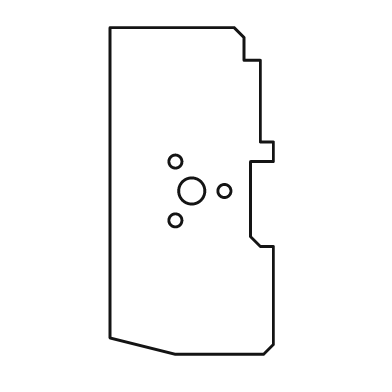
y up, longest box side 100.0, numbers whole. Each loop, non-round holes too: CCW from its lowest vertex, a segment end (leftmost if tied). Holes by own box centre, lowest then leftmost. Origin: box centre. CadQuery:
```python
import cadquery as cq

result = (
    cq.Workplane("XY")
    .moveTo(-5.0, -50.0)
    .lineTo(22.0, -50.0)
    .lineTo(25.0, -47.0)
    .lineTo(25.0, -17.0)
    .lineTo(21.0, -17.0)
    .lineTo(18.0, -14.0)
    .lineTo(18.0, 9.0)
    .lineTo(25.0, 9.0)
    .lineTo(25.0, 15.0)
    .lineTo(21.0, 15.0)
    .lineTo(21.0, 40.0)
    .lineTo(16.0, 40.0)
    .lineTo(16.0, 47.0)
    .lineTo(13.0, 50.0)
    .lineTo(-25.0, 50.0)
    .lineTo(-25.0, -45.0)
    .close()
    .moveTo(-5.0, -9.0)
    .circle(2.0)
    .moveTo(0.0, 0.0)
    .circle(4.0)
    .moveTo(10.0, 0.0)
    .circle(2.0)
    .moveTo(-5.0, 9.0)
    .circle(2.0)
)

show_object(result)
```